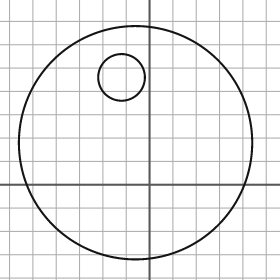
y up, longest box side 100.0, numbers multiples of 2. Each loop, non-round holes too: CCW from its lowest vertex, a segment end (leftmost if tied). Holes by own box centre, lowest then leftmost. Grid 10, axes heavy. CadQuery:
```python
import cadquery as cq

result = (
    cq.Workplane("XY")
    .moveTo(-6.0, 18.0)
    .circle(50.0)
    .moveTo(-12.0, 46.0)
    .circle(10.0)
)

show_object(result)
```